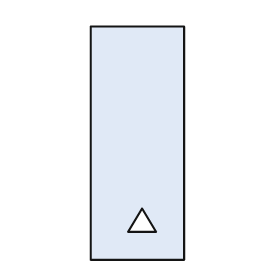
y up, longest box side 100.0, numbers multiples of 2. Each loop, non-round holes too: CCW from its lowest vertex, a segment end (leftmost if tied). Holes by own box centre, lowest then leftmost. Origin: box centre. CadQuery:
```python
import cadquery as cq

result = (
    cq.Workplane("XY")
    .moveTo(-20.0, -50.0)
    .lineTo(20.0, -50.0)
    .lineTo(20.0, 50.0)
    .lineTo(-20.0, 50.0)
    .close()
    .moveTo(-4.0, -38.0)
    .lineTo(8.0, -38.0)
    .lineTo(2.0, -28.0)
    .close()
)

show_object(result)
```